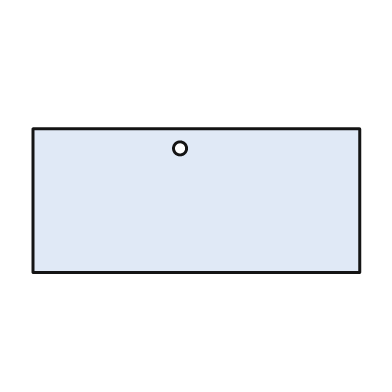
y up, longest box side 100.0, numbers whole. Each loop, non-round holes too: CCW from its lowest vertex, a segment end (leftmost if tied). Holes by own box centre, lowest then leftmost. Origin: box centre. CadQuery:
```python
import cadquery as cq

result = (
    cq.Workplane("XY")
    .moveTo(-50.0, -22.0)
    .lineTo(50.0, -22.0)
    .lineTo(50.0, 22.0)
    .lineTo(-50.0, 22.0)
    .close()
    .moveTo(-5.0, 16.0)
    .circle(2.0)
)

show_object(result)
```